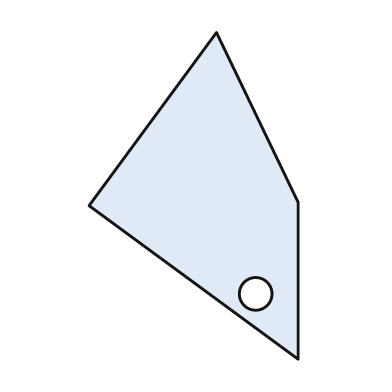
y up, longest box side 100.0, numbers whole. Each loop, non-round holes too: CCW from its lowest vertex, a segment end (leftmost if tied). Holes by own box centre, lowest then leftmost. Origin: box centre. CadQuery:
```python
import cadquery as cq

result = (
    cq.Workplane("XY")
    .moveTo(32.0, -50.0)
    .lineTo(32.0, -2.0)
    .lineTo(7.0, 50.0)
    .lineTo(-32.0, -3.0)
    .close()
    .moveTo(19.0, -30.0)
    .circle(5.0)
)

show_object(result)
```